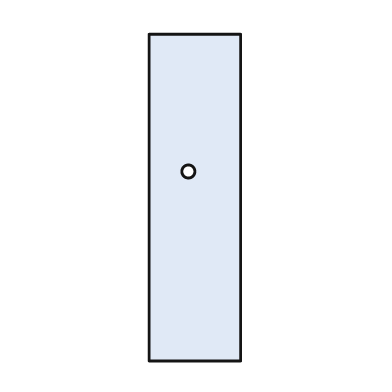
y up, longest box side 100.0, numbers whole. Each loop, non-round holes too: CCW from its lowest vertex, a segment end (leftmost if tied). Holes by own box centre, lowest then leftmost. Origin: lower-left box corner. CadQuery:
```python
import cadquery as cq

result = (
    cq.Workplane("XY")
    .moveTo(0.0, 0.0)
    .lineTo(28.0, 0.0)
    .lineTo(28.0, 100.0)
    .lineTo(0.0, 100.0)
    .close()
    .moveTo(12.0, 58.0)
    .circle(2.0)
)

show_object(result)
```